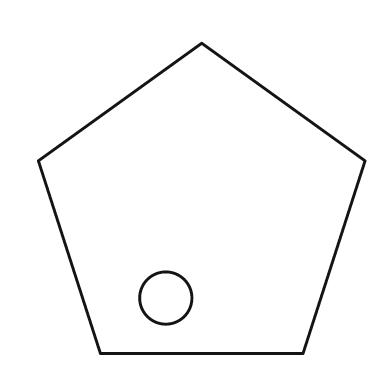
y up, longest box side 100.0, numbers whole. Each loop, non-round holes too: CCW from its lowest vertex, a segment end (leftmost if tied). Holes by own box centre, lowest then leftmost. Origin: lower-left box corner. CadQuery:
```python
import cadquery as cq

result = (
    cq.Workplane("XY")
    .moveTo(19.0, 0.0)
    .lineTo(81.0, 0.0)
    .lineTo(100.0, 59.0)
    .lineTo(50.0, 95.0)
    .lineTo(0.0, 59.0)
    .close()
    .moveTo(39.0, 17.0)
    .circle(8.0)
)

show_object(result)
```